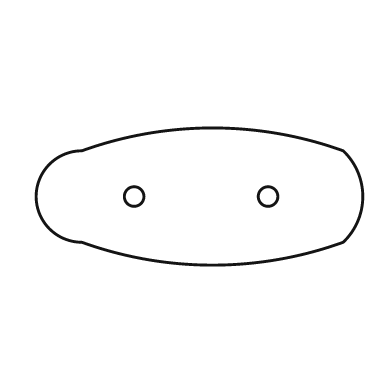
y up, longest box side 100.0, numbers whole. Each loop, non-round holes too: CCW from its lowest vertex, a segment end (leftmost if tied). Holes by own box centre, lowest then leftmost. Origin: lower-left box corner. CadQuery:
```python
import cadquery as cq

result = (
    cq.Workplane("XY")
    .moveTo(14.0, 7.0)
    .threePointArc((54.0, 0.0), (94.0, 7.0))
    .threePointArc((100.0, 21.0), (94.0, 35.0))
    .threePointArc((54.0, 42.0), (14.0, 35.0))
    .threePointArc((0.0, 21.0), (14.0, 7.0))
    .close()
    .moveTo(30.0, 21.0)
    .circle(3.0)
    .moveTo(71.0, 21.0)
    .circle(3.0)
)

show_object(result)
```